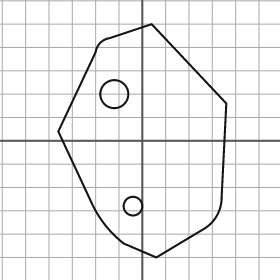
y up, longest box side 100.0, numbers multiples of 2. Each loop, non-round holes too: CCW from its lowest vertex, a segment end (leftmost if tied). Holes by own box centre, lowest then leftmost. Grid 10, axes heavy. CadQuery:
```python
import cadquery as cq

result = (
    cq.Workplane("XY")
    .moveTo(6.0, -50.0)
    .lineTo(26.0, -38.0)
    .threePointArc((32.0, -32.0), (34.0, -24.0))
    .lineTo(36.0, 16.0)
    .lineTo(4.0, 50.0)
    .lineTo(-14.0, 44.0)
    .threePointArc((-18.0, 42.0), (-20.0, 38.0))
    .lineTo(-36.0, 4.0)
    .lineTo(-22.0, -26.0)
    .threePointArc((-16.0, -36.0), (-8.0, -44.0))
    .close()
    .moveTo(-4.0, -28.0)
    .circle(4.0)
    .moveTo(-12.0, 20.0)
    .circle(6.0)
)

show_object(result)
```